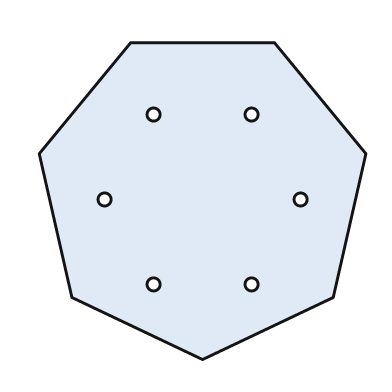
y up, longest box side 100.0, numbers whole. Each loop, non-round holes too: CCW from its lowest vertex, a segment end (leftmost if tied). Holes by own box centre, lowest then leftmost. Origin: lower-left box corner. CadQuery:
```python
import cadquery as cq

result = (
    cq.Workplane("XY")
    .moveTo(50.0, 0.0)
    .lineTo(90.0, 19.0)
    .lineTo(100.0, 63.0)
    .lineTo(72.0, 97.0)
    .lineTo(28.0, 97.0)
    .lineTo(0.0, 63.0)
    .lineTo(10.0, 19.0)
    .close()
    .moveTo(35.0, 23.0)
    .circle(2.0)
    .moveTo(65.0, 23.0)
    .circle(2.0)
    .moveTo(20.0, 49.0)
    .circle(2.0)
    .moveTo(80.0, 49.0)
    .circle(2.0)
    .moveTo(35.0, 75.0)
    .circle(2.0)
    .moveTo(65.0, 75.0)
    .circle(2.0)
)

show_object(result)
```